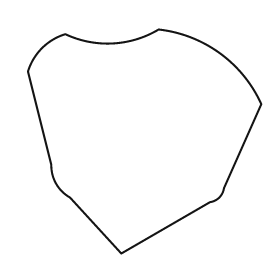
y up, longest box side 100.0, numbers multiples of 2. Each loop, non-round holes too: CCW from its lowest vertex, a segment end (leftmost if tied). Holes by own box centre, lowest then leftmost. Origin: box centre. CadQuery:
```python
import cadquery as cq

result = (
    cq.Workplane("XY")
    .moveTo(-10.0, -48.0)
    .lineTo(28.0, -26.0)
    .threePointArc((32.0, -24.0), (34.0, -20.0))
    .lineTo(50.0, 16.0)
    .threePointArc((32.0, 38.0), (6.0, 48.0))
    .threePointArc((-14.0, 42.0), (-34.0, 46.0))
    .threePointArc((-44.0, 40.0), (-50.0, 30.0))
    .lineTo(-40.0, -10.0)
    .threePointArc((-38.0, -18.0), (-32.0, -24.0))
    .close()
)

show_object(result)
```